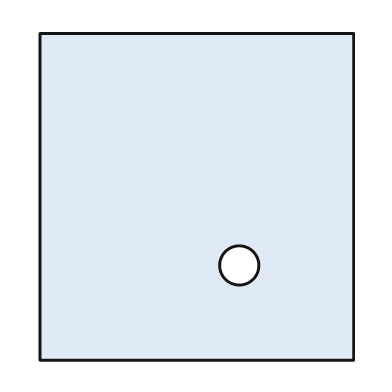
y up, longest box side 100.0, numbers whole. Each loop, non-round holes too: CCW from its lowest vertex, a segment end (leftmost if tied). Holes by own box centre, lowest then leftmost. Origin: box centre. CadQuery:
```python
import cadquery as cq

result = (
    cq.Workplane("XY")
    .moveTo(-48.0, -50.0)
    .lineTo(48.0, -50.0)
    .lineTo(48.0, 50.0)
    .lineTo(-48.0, 50.0)
    .close()
    .moveTo(13.0, -21.0)
    .circle(6.0)
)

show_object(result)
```